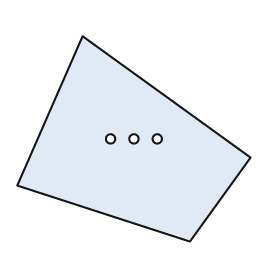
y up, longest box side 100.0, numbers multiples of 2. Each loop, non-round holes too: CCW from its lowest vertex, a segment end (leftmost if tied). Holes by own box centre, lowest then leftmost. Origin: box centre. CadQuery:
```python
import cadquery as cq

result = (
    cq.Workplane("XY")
    .moveTo(24.0, -44.0)
    .lineTo(50.0, -8.0)
    .lineTo(-22.0, 44.0)
    .lineTo(-50.0, -20.0)
    .close()
    .moveTo(-10.0, 0.0)
    .circle(2.0)
    .moveTo(0.0, 0.0)
    .circle(2.0)
    .moveTo(10.0, 0.0)
    .circle(2.0)
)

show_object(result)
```